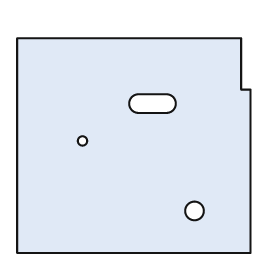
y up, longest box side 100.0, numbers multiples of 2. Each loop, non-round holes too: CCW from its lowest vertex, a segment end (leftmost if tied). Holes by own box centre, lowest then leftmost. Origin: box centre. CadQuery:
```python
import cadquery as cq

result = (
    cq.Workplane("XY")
    .moveTo(-50.0, -46.0)
    .lineTo(50.0, -46.0)
    .lineTo(50.0, 24.0)
    .lineTo(46.0, 24.0)
    .lineTo(46.0, 46.0)
    .lineTo(-50.0, 46.0)
    .close()
    .moveTo(26.0, -28.0)
    .circle(4.0)
    .moveTo(-22.0, 2.0)
    .circle(2.0)
    .moveTo(2.0, 14.0)
    .lineTo(14.0, 14.0)
    .threePointArc((18.0, 18.0), (14.0, 22.0))
    .lineTo(2.0, 22.0)
    .threePointArc((-2.0, 18.0), (2.0, 14.0))
    .close()
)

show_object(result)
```